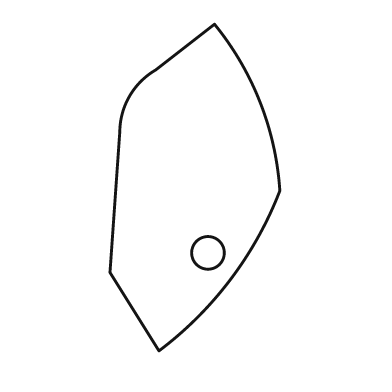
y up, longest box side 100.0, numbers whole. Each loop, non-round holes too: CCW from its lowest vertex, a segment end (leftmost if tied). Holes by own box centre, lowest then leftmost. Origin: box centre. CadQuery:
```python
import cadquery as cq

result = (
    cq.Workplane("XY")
    .moveTo(-11.0, -50.0)
    .threePointArc((11.0, -28.0), (26.0, -1.0))
    .threePointArc((20.0, 26.0), (6.0, 50.0))
    .lineTo(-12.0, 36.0)
    .threePointArc((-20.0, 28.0), (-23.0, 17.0))
    .lineTo(-26.0, -26.0)
    .close()
    .moveTo(4.0, -20.0)
    .circle(5.0)
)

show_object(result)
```